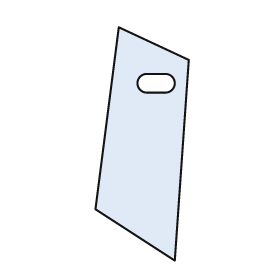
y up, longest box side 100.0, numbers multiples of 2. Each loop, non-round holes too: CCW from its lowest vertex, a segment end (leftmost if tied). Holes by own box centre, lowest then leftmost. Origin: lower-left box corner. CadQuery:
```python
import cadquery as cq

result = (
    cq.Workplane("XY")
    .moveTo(34.0, 0.0)
    .lineTo(40.0, 86.0)
    .lineTo(10.0, 100.0)
    .lineTo(0.0, 22.0)
    .close()
    .moveTo(22.0, 72.0)
    .lineTo(30.0, 72.0)
    .threePointArc((34.0, 76.0), (30.0, 80.0))
    .lineTo(22.0, 80.0)
    .threePointArc((18.0, 76.0), (22.0, 72.0))
    .close()
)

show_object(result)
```